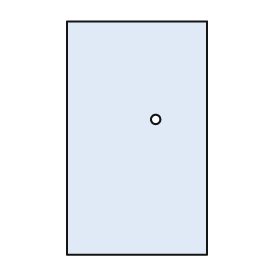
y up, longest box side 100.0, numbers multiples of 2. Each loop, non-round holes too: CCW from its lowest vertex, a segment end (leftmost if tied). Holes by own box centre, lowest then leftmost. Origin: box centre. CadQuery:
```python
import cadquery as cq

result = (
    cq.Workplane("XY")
    .moveTo(-30.0, -50.0)
    .lineTo(30.0, -50.0)
    .lineTo(30.0, 50.0)
    .lineTo(-30.0, 50.0)
    .close()
    .moveTo(8.0, 8.0)
    .circle(2.0)
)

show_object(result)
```